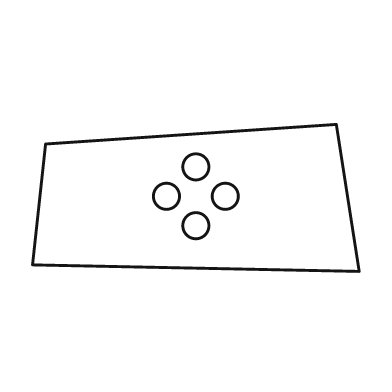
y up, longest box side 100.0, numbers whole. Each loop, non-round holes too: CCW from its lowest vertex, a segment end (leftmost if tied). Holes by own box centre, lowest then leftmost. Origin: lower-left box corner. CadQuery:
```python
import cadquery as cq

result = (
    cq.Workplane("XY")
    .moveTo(100.0, 0.0)
    .lineTo(93.0, 45.0)
    .lineTo(4.0, 39.0)
    .lineTo(0.0, 2.0)
    .close()
    .moveTo(50.0, 14.0)
    .circle(4.0)
    .moveTo(41.0, 23.0)
    .circle(4.0)
    .moveTo(59.0, 23.0)
    .circle(4.0)
    .moveTo(50.0, 32.0)
    .circle(4.0)
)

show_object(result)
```